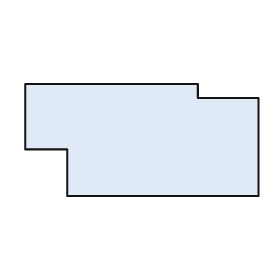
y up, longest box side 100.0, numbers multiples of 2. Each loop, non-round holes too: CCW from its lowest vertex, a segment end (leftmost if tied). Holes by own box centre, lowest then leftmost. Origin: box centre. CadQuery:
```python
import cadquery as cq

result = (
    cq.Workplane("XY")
    .moveTo(-32.0, -24.0)
    .lineTo(50.0, -24.0)
    .lineTo(50.0, 18.0)
    .lineTo(24.0, 18.0)
    .lineTo(24.0, 24.0)
    .lineTo(-50.0, 24.0)
    .lineTo(-50.0, -4.0)
    .lineTo(-32.0, -4.0)
    .close()
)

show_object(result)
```